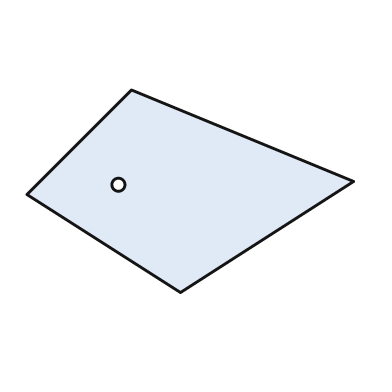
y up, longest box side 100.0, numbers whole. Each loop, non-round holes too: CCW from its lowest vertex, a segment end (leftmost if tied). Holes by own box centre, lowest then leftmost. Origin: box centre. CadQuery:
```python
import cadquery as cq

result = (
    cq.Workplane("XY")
    .moveTo(-3.0, -31.0)
    .lineTo(50.0, 3.0)
    .lineTo(-18.0, 31.0)
    .lineTo(-50.0, -1.0)
    .close()
    .moveTo(-22.0, 2.0)
    .circle(2.0)
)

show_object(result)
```